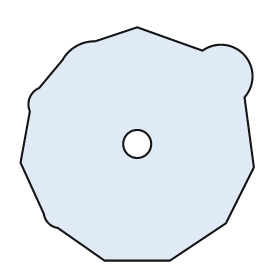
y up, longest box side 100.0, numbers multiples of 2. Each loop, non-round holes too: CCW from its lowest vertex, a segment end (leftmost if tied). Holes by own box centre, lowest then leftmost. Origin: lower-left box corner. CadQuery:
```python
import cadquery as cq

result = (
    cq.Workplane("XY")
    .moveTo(36.0, 0.0)
    .lineTo(64.0, 0.0)
    .lineTo(88.0, 16.0)
    .lineTo(100.0, 40.0)
    .lineTo(96.0, 70.0)
    .threePointArc((96.0, 88.0), (78.0, 90.0))
    .lineTo(50.0, 100.0)
    .lineTo(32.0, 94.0)
    .threePointArc((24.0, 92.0), (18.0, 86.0))
    .lineTo(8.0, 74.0)
    .threePointArc((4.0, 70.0), (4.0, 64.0))
    .lineTo(0.0, 42.0)
    .lineTo(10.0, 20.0)
    .threePointArc((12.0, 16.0), (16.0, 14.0))
    .close()
    .moveTo(50.0, 50.0)
    .circle(6.0)
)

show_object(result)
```